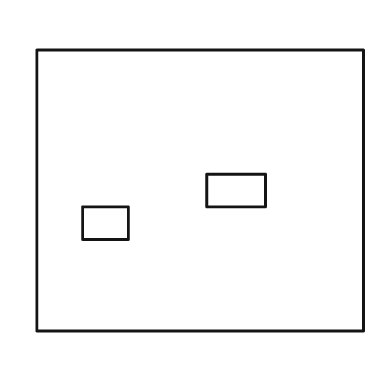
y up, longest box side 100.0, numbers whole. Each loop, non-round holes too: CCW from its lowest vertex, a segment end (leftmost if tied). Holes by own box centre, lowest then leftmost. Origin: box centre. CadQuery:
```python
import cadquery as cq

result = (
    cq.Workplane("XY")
    .moveTo(-50.0, -43.0)
    .lineTo(50.0, -43.0)
    .lineTo(50.0, 43.0)
    .lineTo(-50.0, 43.0)
    .close()
    .moveTo(-36.0, -15.0)
    .lineTo(-22.0, -15.0)
    .lineTo(-22.0, -5.0)
    .lineTo(-36.0, -5.0)
    .close()
    .moveTo(2.0, -5.0)
    .lineTo(20.0, -5.0)
    .lineTo(20.0, 5.0)
    .lineTo(2.0, 5.0)
    .close()
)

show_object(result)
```